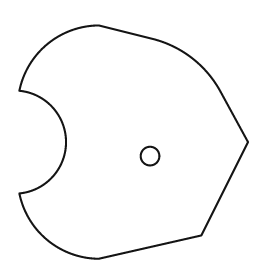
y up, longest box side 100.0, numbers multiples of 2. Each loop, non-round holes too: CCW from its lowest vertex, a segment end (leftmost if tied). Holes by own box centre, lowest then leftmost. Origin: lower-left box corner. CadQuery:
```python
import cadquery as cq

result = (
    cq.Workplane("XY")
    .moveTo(34.0, 0.0)
    .lineTo(78.0, 10.0)
    .lineTo(98.0, 50.0)
    .lineTo(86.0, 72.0)
    .threePointArc((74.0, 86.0), (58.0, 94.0))
    .lineTo(34.0, 100.0)
    .threePointArc((12.0, 92.0), (0.0, 72.0))
    .threePointArc((20.0, 50.0), (0.0, 28.0))
    .threePointArc((12.0, 8.0), (34.0, 0.0))
    .close()
    .moveTo(56.0, 44.0)
    .circle(4.0)
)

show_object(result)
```